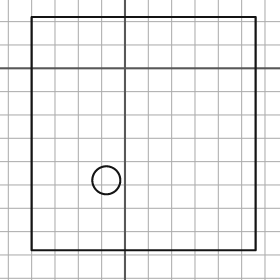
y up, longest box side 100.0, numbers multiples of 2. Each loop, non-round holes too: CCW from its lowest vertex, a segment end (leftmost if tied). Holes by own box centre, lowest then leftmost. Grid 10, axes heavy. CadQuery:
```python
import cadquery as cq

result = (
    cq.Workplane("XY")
    .moveTo(-40.0, -78.0)
    .lineTo(56.0, -78.0)
    .lineTo(56.0, 22.0)
    .lineTo(-40.0, 22.0)
    .close()
    .moveTo(-8.0, -48.0)
    .circle(6.0)
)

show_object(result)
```